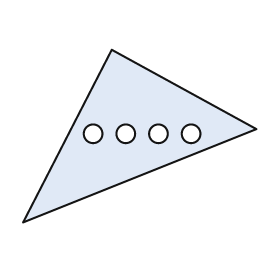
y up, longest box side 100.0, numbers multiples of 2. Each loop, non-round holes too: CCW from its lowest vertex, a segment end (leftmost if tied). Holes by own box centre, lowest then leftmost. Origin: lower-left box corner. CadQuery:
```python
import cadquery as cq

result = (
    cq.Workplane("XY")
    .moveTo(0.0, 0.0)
    .lineTo(100.0, 40.0)
    .lineTo(38.0, 74.0)
    .close()
    .moveTo(30.0, 38.0)
    .circle(4.0)
    .moveTo(44.0, 38.0)
    .circle(4.0)
    .moveTo(58.0, 38.0)
    .circle(4.0)
    .moveTo(72.0, 38.0)
    .circle(4.0)
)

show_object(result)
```